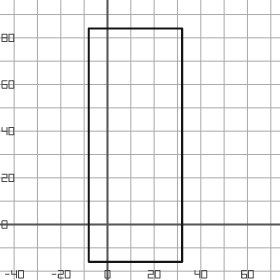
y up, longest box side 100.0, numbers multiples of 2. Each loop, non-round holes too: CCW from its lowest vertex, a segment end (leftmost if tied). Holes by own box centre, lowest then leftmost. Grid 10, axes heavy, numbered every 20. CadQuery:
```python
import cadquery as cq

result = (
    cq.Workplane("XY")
    .moveTo(-8.0, -16.0)
    .lineTo(32.0, -16.0)
    .lineTo(32.0, 84.0)
    .lineTo(-8.0, 84.0)
    .close()
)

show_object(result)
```